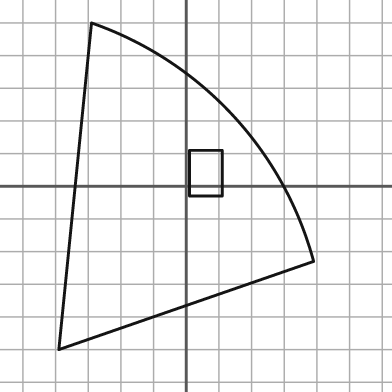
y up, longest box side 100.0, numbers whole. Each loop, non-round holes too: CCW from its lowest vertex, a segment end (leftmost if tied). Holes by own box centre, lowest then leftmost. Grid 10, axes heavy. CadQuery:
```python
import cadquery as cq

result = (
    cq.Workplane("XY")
    .moveTo(-39.0, -50.0)
    .lineTo(39.0, -23.0)
    .threePointArc((14.0, 22.0), (-29.0, 50.0))
    .close()
    .moveTo(1.0, -3.0)
    .lineTo(11.0, -3.0)
    .lineTo(11.0, 11.0)
    .lineTo(1.0, 11.0)
    .close()
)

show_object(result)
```